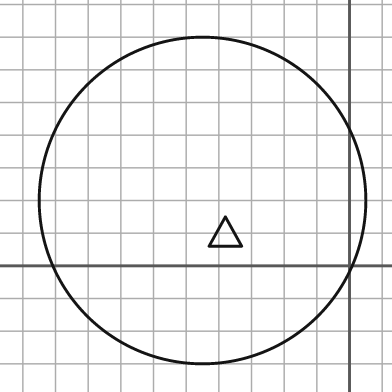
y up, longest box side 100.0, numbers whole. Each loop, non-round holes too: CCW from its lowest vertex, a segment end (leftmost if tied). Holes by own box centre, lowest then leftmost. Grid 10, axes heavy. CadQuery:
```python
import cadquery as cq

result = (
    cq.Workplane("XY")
    .moveTo(-45.0, 20.0)
    .circle(50.0)
    .moveTo(-43.0, 6.0)
    .lineTo(-33.0, 6.0)
    .lineTo(-38.0, 15.0)
    .close()
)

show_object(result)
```